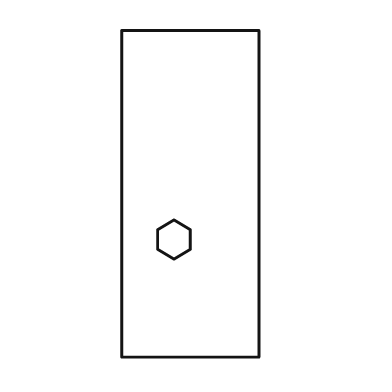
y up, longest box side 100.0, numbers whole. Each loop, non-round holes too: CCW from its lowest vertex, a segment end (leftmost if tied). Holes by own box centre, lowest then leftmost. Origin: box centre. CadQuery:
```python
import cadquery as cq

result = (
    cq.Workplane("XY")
    .moveTo(-21.0, -50.0)
    .lineTo(21.0, -50.0)
    .lineTo(21.0, 50.0)
    .lineTo(-21.0, 50.0)
    .close()
    .moveTo(-5.0, -20.0)
    .lineTo(0.0, -17.0)
    .lineTo(0.0, -11.0)
    .lineTo(-5.0, -8.0)
    .lineTo(-10.0, -11.0)
    .lineTo(-10.0, -17.0)
    .close()
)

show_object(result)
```